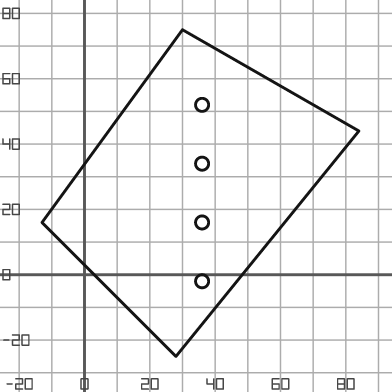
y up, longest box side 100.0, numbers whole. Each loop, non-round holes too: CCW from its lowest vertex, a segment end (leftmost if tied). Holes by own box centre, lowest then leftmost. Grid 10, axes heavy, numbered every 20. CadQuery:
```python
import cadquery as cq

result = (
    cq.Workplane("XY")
    .moveTo(28.0, -25.0)
    .lineTo(84.0, 44.0)
    .lineTo(30.0, 75.0)
    .lineTo(-13.0, 16.0)
    .close()
    .moveTo(36.0, -2.0)
    .circle(2.0)
    .moveTo(36.0, 16.0)
    .circle(2.0)
    .moveTo(36.0, 34.0)
    .circle(2.0)
    .moveTo(36.0, 52.0)
    .circle(2.0)
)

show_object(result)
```